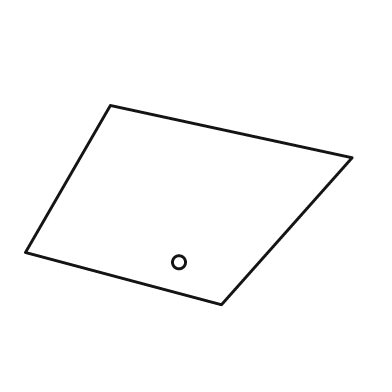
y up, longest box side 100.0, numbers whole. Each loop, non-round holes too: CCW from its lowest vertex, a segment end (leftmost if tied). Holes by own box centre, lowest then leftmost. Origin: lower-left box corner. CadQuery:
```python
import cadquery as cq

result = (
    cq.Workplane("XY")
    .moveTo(60.0, 0.0)
    .lineTo(100.0, 45.0)
    .lineTo(26.0, 61.0)
    .lineTo(0.0, 16.0)
    .close()
    .moveTo(47.0, 13.0)
    .circle(2.0)
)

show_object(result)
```